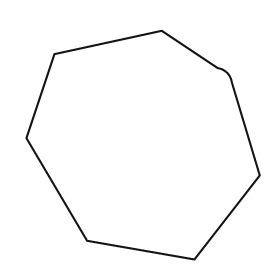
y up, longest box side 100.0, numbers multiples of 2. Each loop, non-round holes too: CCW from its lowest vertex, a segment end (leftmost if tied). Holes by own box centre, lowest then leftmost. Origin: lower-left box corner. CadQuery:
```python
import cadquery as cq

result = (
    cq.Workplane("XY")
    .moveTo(72.0, 0.0)
    .lineTo(100.0, 36.0)
    .lineTo(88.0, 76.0)
    .threePointArc((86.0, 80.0), (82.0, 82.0))
    .lineTo(58.0, 98.0)
    .lineTo(12.0, 88.0)
    .lineTo(0.0, 52.0)
    .lineTo(26.0, 8.0)
    .close()
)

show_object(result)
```